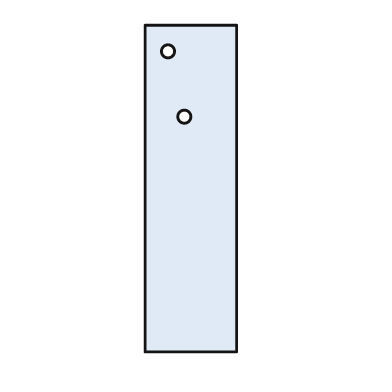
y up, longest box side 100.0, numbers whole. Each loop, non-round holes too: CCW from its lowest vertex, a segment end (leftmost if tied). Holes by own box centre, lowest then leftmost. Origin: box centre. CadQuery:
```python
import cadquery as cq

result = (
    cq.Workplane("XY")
    .moveTo(-14.0, -50.0)
    .lineTo(14.0, -50.0)
    .lineTo(14.0, 50.0)
    .lineTo(-14.0, 50.0)
    .close()
    .moveTo(-2.0, 22.0)
    .circle(2.0)
    .moveTo(-7.0, 42.0)
    .circle(2.0)
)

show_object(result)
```